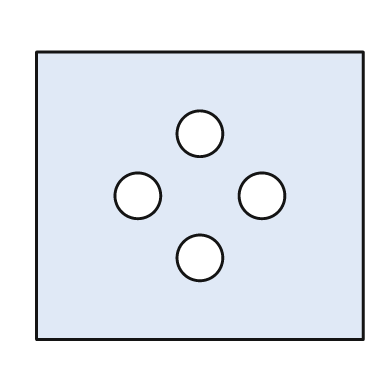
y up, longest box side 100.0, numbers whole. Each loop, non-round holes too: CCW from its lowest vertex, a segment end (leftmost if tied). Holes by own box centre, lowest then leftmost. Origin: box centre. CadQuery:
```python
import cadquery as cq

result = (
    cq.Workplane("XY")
    .moveTo(-50.0, -44.0)
    .lineTo(50.0, -44.0)
    .lineTo(50.0, 44.0)
    .lineTo(-50.0, 44.0)
    .close()
    .moveTo(0.0, -19.0)
    .circle(7.0)
    .moveTo(-19.0, 0.0)
    .circle(7.0)
    .moveTo(19.0, 0.0)
    .circle(7.0)
    .moveTo(0.0, 19.0)
    .circle(7.0)
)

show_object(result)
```